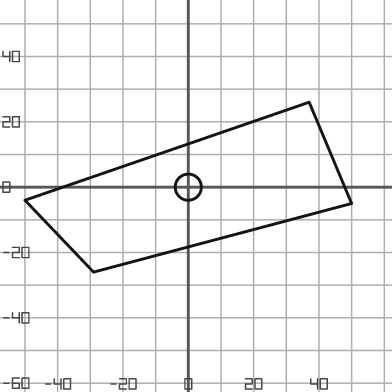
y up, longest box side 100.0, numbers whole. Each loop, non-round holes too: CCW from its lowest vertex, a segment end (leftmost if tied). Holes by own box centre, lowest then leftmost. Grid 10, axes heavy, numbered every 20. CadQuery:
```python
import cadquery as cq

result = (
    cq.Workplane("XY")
    .moveTo(-29.0, -26.0)
    .lineTo(50.0, -5.0)
    .lineTo(37.0, 26.0)
    .lineTo(-50.0, -4.0)
    .close()
    .moveTo(0.0, 0.0)
    .circle(4.0)
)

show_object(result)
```